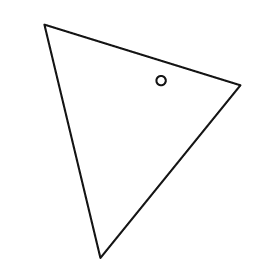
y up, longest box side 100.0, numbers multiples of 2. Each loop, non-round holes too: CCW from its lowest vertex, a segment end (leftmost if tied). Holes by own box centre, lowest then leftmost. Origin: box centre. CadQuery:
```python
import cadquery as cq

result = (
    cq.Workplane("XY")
    .moveTo(-18.0, -50.0)
    .lineTo(42.0, 24.0)
    .lineTo(-42.0, 50.0)
    .close()
    .moveTo(8.0, 26.0)
    .circle(2.0)
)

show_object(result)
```